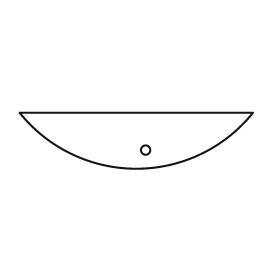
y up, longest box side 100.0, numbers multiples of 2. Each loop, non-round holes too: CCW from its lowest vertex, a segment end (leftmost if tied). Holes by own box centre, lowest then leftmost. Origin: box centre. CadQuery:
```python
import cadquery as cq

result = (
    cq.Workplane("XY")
    .moveTo(-50.0, 12.0)
    .threePointArc((0.0, -12.0), (50.0, 12.0))
    .close()
    .moveTo(4.0, -4.0)
    .circle(2.0)
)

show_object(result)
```